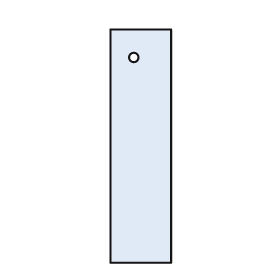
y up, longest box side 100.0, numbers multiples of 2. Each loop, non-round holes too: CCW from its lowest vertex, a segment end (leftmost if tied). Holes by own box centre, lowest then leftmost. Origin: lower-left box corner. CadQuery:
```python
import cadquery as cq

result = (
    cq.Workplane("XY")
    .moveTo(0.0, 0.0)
    .lineTo(26.0, 0.0)
    .lineTo(26.0, 100.0)
    .lineTo(0.0, 100.0)
    .close()
    .moveTo(10.0, 88.0)
    .circle(2.0)
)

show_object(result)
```